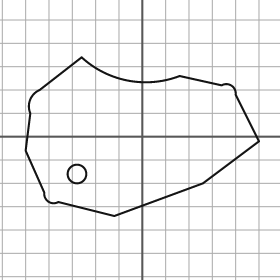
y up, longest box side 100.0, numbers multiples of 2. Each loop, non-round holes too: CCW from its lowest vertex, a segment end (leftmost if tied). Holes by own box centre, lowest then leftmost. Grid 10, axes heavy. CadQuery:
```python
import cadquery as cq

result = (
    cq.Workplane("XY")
    .moveTo(-12.0, -34.0)
    .lineTo(26.0, -20.0)
    .lineTo(50.0, -2.0)
    .lineTo(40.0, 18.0)
    .threePointArc((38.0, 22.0), (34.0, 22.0))
    .lineTo(16.0, 26.0)
    .threePointArc((-6.0, 24.0), (-26.0, 34.0))
    .lineTo(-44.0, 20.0)
    .threePointArc((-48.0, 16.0), (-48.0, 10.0))
    .lineTo(-50.0, -6.0)
    .lineTo(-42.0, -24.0)
    .threePointArc((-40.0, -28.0), (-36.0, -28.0))
    .close()
    .moveTo(-28.0, -16.0)
    .circle(4.0)
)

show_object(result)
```